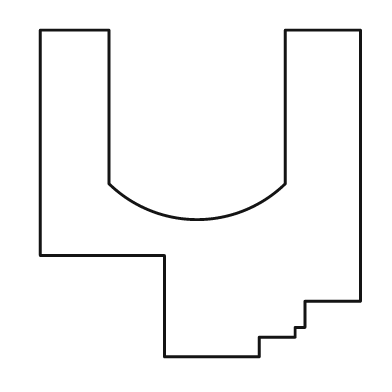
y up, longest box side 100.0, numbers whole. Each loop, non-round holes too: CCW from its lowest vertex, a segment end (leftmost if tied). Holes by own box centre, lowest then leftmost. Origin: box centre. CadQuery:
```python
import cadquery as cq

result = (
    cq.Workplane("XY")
    .moveTo(-11.0, -50.0)
    .lineTo(18.0, -50.0)
    .lineTo(18.0, -44.0)
    .lineTo(29.0, -44.0)
    .lineTo(29.0, -41.0)
    .lineTo(32.0, -41.0)
    .lineTo(32.0, -33.0)
    .lineTo(49.0, -33.0)
    .lineTo(49.0, 50.0)
    .lineTo(26.0, 50.0)
    .lineTo(26.0, 3.0)
    .threePointArc((-1.0, -8.0), (-28.0, 3.0))
    .lineTo(-28.0, 50.0)
    .lineTo(-49.0, 50.0)
    .lineTo(-49.0, -19.0)
    .lineTo(-11.0, -19.0)
    .close()
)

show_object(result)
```